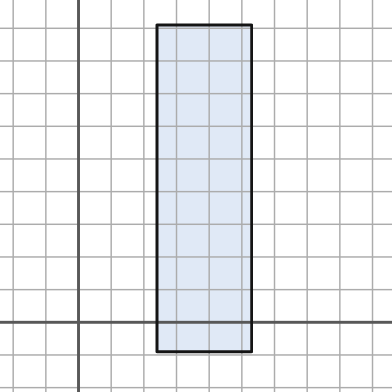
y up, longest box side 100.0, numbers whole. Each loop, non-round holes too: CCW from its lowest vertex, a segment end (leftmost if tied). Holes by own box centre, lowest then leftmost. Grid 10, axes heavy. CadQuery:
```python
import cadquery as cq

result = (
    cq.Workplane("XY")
    .moveTo(24.0, -9.0)
    .lineTo(53.0, -9.0)
    .lineTo(53.0, 91.0)
    .lineTo(24.0, 91.0)
    .close()
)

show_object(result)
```